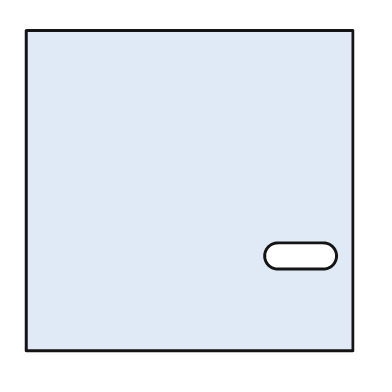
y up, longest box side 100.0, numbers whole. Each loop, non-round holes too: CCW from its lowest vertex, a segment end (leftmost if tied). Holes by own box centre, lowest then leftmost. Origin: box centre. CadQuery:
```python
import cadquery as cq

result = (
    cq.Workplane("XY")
    .moveTo(-50.0, -49.0)
    .lineTo(50.0, -49.0)
    .lineTo(50.0, 49.0)
    .lineTo(-50.0, 49.0)
    .close()
    .moveTo(27.0, -24.0)
    .lineTo(41.0, -24.0)
    .threePointArc((45.0, -20.0), (41.0, -16.0))
    .lineTo(27.0, -16.0)
    .threePointArc((23.0, -20.0), (27.0, -24.0))
    .close()
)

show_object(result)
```